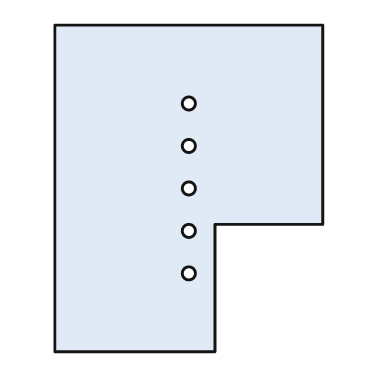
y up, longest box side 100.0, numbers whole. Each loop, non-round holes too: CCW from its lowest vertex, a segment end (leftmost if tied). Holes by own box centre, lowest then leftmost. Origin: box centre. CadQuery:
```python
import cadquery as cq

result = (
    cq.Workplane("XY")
    .moveTo(-41.0, -50.0)
    .lineTo(8.0, -50.0)
    .lineTo(8.0, -11.0)
    .lineTo(41.0, -11.0)
    .lineTo(41.0, 50.0)
    .lineTo(-41.0, 50.0)
    .close()
    .moveTo(0.0, -26.0)
    .circle(2.0)
    .moveTo(0.0, -13.0)
    .circle(2.0)
    .moveTo(0.0, 0.0)
    .circle(2.0)
    .moveTo(0.0, 13.0)
    .circle(2.0)
    .moveTo(0.0, 26.0)
    .circle(2.0)
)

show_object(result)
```